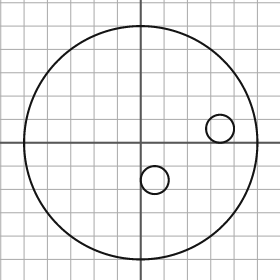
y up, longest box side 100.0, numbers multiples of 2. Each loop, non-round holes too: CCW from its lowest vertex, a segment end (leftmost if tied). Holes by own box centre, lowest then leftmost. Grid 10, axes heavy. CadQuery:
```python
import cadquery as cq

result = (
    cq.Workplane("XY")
    .moveTo(0.0, 0.0)
    .circle(50.0)
    .moveTo(6.0, -16.0)
    .circle(6.0)
    .moveTo(34.0, 6.0)
    .circle(6.0)
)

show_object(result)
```